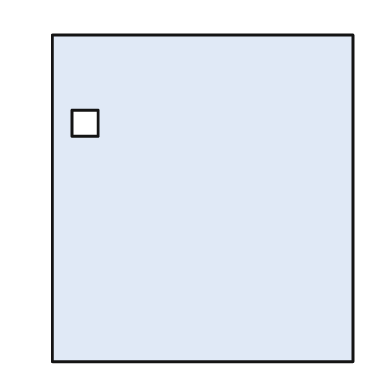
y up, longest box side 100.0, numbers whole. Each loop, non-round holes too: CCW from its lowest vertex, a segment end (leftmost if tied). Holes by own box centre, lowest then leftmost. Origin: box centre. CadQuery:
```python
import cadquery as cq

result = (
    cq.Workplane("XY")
    .moveTo(-46.0, -50.0)
    .lineTo(46.0, -50.0)
    .lineTo(46.0, 50.0)
    .lineTo(-46.0, 50.0)
    .close()
    .moveTo(-40.0, 19.0)
    .lineTo(-32.0, 19.0)
    .lineTo(-32.0, 27.0)
    .lineTo(-40.0, 27.0)
    .close()
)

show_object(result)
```